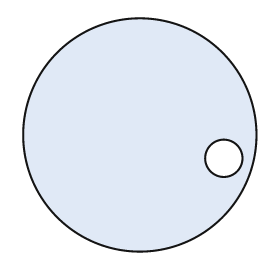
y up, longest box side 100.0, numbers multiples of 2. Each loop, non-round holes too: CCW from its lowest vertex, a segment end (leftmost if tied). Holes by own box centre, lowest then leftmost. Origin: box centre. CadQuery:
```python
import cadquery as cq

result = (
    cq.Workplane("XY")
    .moveTo(0.0, 0.0)
    .circle(50.0)
    .moveTo(36.0, -10.0)
    .circle(8.0)
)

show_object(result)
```